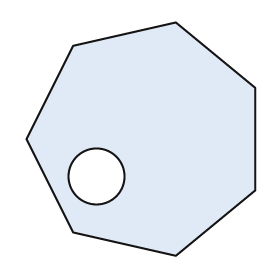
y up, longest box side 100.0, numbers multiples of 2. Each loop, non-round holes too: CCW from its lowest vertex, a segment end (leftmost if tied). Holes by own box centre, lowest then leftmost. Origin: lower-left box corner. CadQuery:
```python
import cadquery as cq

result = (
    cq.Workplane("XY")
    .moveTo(64.0, 0.0)
    .lineTo(98.0, 28.0)
    .lineTo(98.0, 72.0)
    .lineTo(64.0, 100.0)
    .lineTo(20.0, 90.0)
    .lineTo(0.0, 50.0)
    .lineTo(20.0, 10.0)
    .close()
    .moveTo(30.0, 34.0)
    .circle(12.0)
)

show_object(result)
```